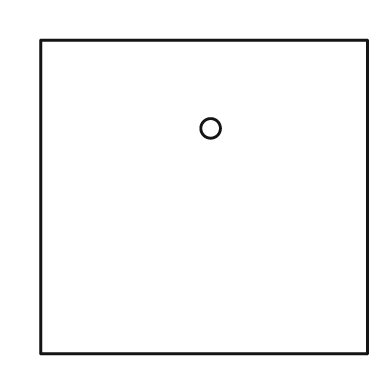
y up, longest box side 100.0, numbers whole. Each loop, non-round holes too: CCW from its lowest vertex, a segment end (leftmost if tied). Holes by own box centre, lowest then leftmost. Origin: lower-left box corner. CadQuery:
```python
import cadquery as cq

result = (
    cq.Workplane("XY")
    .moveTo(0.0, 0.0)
    .lineTo(100.0, 0.0)
    .lineTo(100.0, 96.0)
    .lineTo(0.0, 96.0)
    .close()
    .moveTo(52.0, 69.0)
    .circle(3.0)
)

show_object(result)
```